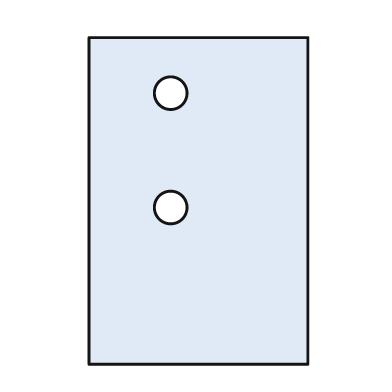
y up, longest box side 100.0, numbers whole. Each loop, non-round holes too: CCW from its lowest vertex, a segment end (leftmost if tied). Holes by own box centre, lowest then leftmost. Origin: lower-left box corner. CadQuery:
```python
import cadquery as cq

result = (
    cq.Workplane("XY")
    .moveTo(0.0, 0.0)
    .lineTo(67.0, 0.0)
    .lineTo(67.0, 100.0)
    .lineTo(0.0, 100.0)
    .close()
    .moveTo(25.0, 48.0)
    .circle(5.0)
    .moveTo(25.0, 83.0)
    .circle(5.0)
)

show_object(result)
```